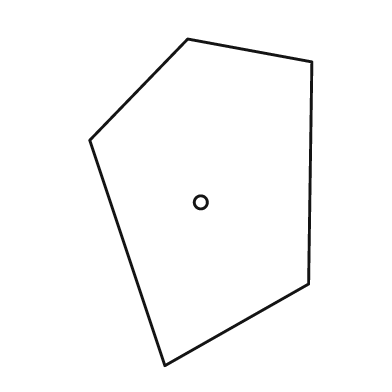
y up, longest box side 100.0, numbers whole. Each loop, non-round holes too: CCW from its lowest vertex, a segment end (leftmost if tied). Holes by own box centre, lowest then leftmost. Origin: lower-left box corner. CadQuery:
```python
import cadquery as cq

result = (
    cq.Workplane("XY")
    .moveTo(23.0, 0.0)
    .lineTo(67.0, 25.0)
    .lineTo(68.0, 93.0)
    .lineTo(30.0, 100.0)
    .lineTo(0.0, 69.0)
    .close()
    .moveTo(34.0, 50.0)
    .circle(2.0)
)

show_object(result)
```